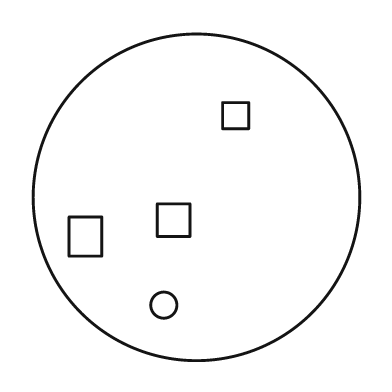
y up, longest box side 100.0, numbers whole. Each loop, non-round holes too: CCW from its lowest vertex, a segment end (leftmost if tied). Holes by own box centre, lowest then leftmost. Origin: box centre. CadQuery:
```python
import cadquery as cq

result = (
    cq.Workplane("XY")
    .moveTo(0.0, 0.0)
    .circle(50.0)
    .moveTo(-10.0, -33.0)
    .circle(4.0)
    .moveTo(-39.0, -18.0)
    .lineTo(-29.0, -18.0)
    .lineTo(-29.0, -6.0)
    .lineTo(-39.0, -6.0)
    .close()
    .moveTo(-12.0, -12.0)
    .lineTo(-2.0, -12.0)
    .lineTo(-2.0, -2.0)
    .lineTo(-12.0, -2.0)
    .close()
    .moveTo(8.0, 21.0)
    .lineTo(16.0, 21.0)
    .lineTo(16.0, 29.0)
    .lineTo(8.0, 29.0)
    .close()
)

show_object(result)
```